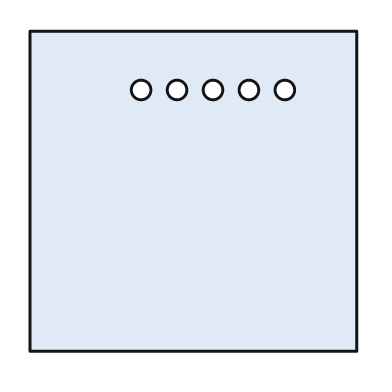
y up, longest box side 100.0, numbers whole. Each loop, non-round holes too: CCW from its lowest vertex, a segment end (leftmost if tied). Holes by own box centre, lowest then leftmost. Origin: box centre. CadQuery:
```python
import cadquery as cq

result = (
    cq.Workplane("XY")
    .moveTo(-50.0, -49.0)
    .lineTo(50.0, -49.0)
    .lineTo(50.0, 49.0)
    .lineTo(-50.0, 49.0)
    .close()
    .moveTo(-16.0, 31.0)
    .circle(3.0)
    .moveTo(-5.0, 31.0)
    .circle(3.0)
    .moveTo(6.0, 31.0)
    .circle(3.0)
    .moveTo(17.0, 31.0)
    .circle(3.0)
    .moveTo(28.0, 31.0)
    .circle(3.0)
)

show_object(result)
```